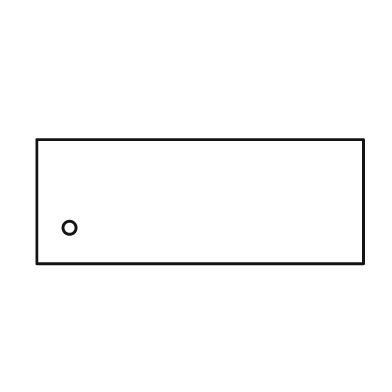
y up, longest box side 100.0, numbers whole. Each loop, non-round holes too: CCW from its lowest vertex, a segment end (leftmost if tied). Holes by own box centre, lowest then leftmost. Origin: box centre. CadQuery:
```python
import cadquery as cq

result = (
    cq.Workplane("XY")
    .moveTo(-50.0, -19.0)
    .lineTo(50.0, -19.0)
    .lineTo(50.0, 19.0)
    .lineTo(-50.0, 19.0)
    .close()
    .moveTo(-40.0, -8.0)
    .circle(2.0)
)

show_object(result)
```